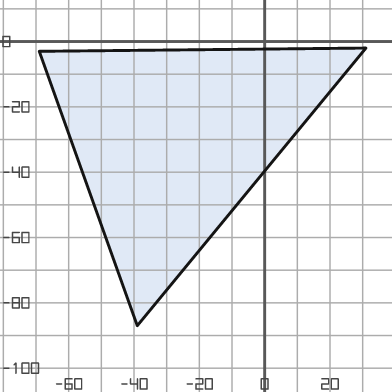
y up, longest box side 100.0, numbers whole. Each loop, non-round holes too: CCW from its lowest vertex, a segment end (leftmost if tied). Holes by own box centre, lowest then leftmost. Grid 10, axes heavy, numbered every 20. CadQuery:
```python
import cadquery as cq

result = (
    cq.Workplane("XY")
    .moveTo(-39.0, -87.0)
    .lineTo(31.0, -2.0)
    .lineTo(-69.0, -3.0)
    .close()
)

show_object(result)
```